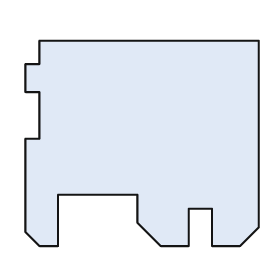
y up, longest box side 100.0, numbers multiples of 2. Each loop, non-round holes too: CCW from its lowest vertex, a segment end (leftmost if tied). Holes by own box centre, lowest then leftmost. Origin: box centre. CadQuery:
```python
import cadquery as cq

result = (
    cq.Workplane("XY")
    .moveTo(-44.0, -44.0)
    .lineTo(-36.0, -44.0)
    .lineTo(-36.0, -22.0)
    .lineTo(-2.0, -22.0)
    .lineTo(-2.0, -34.0)
    .lineTo(8.0, -44.0)
    .lineTo(20.0, -44.0)
    .lineTo(20.0, -28.0)
    .lineTo(30.0, -28.0)
    .lineTo(30.0, -44.0)
    .lineTo(42.0, -44.0)
    .lineTo(50.0, -36.0)
    .lineTo(50.0, 44.0)
    .lineTo(-44.0, 44.0)
    .lineTo(-44.0, 34.0)
    .lineTo(-50.0, 34.0)
    .lineTo(-50.0, 22.0)
    .lineTo(-44.0, 22.0)
    .lineTo(-44.0, 2.0)
    .lineTo(-50.0, 2.0)
    .lineTo(-50.0, -38.0)
    .close()
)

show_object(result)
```